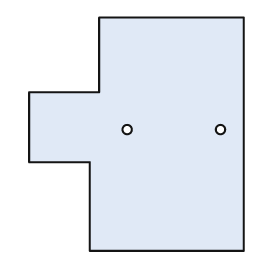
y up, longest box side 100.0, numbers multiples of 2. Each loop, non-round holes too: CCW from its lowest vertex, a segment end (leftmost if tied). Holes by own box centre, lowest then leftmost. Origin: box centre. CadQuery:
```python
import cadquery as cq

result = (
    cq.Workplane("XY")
    .moveTo(-20.0, -50.0)
    .lineTo(46.0, -50.0)
    .lineTo(46.0, 50.0)
    .lineTo(-16.0, 50.0)
    .lineTo(-16.0, 18.0)
    .lineTo(-46.0, 18.0)
    .lineTo(-46.0, -12.0)
    .lineTo(-20.0, -12.0)
    .close()
    .moveTo(-4.0, 2.0)
    .circle(2.0)
    .moveTo(36.0, 2.0)
    .circle(2.0)
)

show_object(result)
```